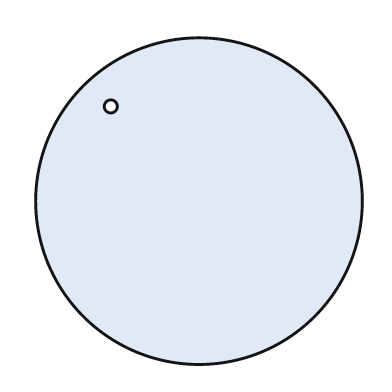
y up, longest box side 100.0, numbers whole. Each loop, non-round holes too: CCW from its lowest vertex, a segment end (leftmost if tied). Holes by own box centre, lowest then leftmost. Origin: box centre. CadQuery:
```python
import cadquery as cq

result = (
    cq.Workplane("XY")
    .moveTo(0.0, 0.0)
    .circle(50.0)
    .moveTo(-27.0, 29.0)
    .circle(2.0)
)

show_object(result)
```